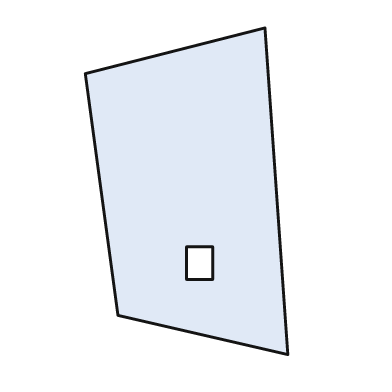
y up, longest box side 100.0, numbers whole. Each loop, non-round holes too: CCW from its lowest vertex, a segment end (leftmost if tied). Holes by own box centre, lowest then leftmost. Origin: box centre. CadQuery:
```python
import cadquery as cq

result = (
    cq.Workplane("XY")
    .moveTo(31.0, -50.0)
    .lineTo(24.0, 50.0)
    .lineTo(-31.0, 36.0)
    .lineTo(-21.0, -38.0)
    .close()
    .moveTo(0.0, -27.0)
    .lineTo(8.0, -27.0)
    .lineTo(8.0, -17.0)
    .lineTo(0.0, -17.0)
    .close()
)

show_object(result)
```